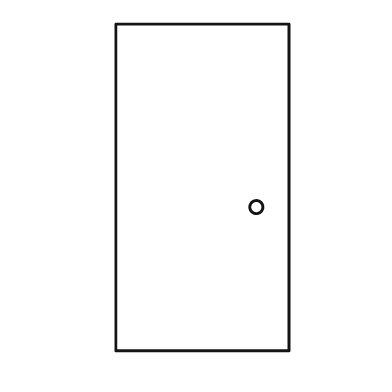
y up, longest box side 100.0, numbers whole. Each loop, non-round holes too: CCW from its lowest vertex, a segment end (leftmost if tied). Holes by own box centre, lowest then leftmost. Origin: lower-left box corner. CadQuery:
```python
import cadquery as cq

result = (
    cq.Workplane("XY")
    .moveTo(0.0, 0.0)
    .lineTo(53.0, 0.0)
    .lineTo(53.0, 100.0)
    .lineTo(0.0, 100.0)
    .close()
    .moveTo(43.0, 44.0)
    .circle(2.0)
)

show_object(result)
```